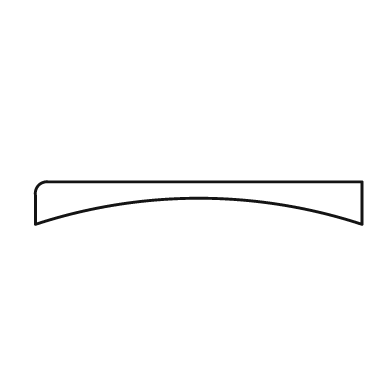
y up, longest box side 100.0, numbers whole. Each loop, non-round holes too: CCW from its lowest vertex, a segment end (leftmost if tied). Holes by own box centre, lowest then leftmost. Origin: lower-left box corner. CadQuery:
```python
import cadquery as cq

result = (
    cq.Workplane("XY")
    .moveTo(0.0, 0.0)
    .threePointArc((50.0, 8.0), (100.0, 0.0))
    .lineTo(100.0, 13.0)
    .lineTo(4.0, 13.0)
    .threePointArc((1.0, 12.0), (0.0, 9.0))
    .close()
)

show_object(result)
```